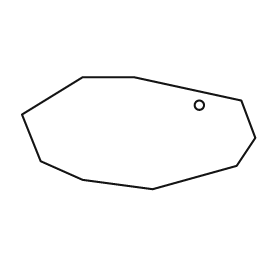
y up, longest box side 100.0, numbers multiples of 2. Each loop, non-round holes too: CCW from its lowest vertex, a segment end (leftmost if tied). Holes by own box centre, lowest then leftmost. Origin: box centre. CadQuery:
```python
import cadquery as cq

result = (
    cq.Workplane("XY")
    .moveTo(6.0, -24.0)
    .lineTo(42.0, -14.0)
    .lineTo(50.0, -2.0)
    .lineTo(44.0, 14.0)
    .lineTo(-2.0, 24.0)
    .lineTo(-24.0, 24.0)
    .lineTo(-50.0, 8.0)
    .lineTo(-42.0, -12.0)
    .lineTo(-24.0, -20.0)
    .close()
    .moveTo(26.0, 12.0)
    .circle(2.0)
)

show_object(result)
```